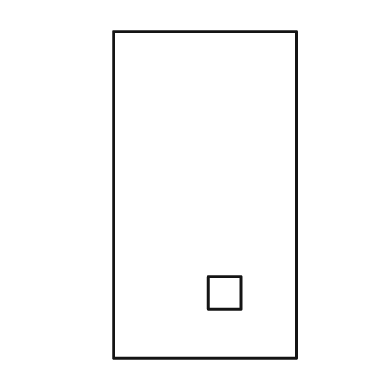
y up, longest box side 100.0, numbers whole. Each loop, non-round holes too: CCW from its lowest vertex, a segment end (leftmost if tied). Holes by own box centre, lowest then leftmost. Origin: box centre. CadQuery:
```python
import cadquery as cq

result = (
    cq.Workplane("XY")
    .moveTo(-28.0, -50.0)
    .lineTo(28.0, -50.0)
    .lineTo(28.0, 50.0)
    .lineTo(-28.0, 50.0)
    .close()
    .moveTo(1.0, -35.0)
    .lineTo(11.0, -35.0)
    .lineTo(11.0, -25.0)
    .lineTo(1.0, -25.0)
    .close()
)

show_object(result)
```